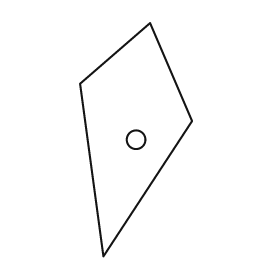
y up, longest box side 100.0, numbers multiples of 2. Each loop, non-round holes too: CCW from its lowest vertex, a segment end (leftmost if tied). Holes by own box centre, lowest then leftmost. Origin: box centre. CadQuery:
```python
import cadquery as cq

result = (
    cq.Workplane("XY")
    .moveTo(-14.0, -50.0)
    .lineTo(24.0, 8.0)
    .lineTo(6.0, 50.0)
    .lineTo(-24.0, 24.0)
    .close()
    .moveTo(0.0, 0.0)
    .circle(4.0)
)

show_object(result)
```